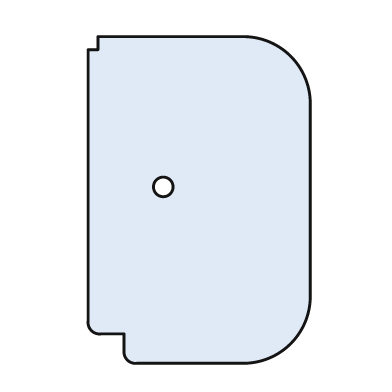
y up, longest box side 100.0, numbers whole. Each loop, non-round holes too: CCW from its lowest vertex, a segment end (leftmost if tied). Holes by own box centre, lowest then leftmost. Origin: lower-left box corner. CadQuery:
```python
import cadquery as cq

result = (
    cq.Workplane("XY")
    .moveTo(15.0, 0.0)
    .lineTo(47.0, 0.0)
    .threePointArc((62.0, 6.0), (68.0, 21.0))
    .lineTo(68.0, 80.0)
    .threePointArc((62.0, 94.0), (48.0, 100.0))
    .lineTo(3.0, 100.0)
    .lineTo(3.0, 96.0)
    .lineTo(0.0, 96.0)
    .lineTo(0.0, 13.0)
    .threePointArc((1.0, 10.0), (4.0, 9.0))
    .lineTo(11.0, 9.0)
    .lineTo(11.0, 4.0)
    .threePointArc((12.0, 1.0), (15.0, 0.0))
    .close()
    .moveTo(23.0, 54.0)
    .circle(3.0)
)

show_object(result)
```